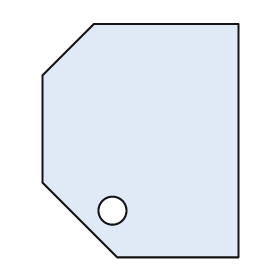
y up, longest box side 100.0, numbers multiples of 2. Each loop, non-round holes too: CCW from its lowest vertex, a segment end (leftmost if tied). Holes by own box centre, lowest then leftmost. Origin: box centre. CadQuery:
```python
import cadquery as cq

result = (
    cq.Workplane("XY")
    .moveTo(-10.0, -50.0)
    .lineTo(42.0, -50.0)
    .lineTo(42.0, 50.0)
    .lineTo(-20.0, 50.0)
    .lineTo(-42.0, 28.0)
    .lineTo(-42.0, -18.0)
    .close()
    .moveTo(-12.0, -30.0)
    .circle(6.0)
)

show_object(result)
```